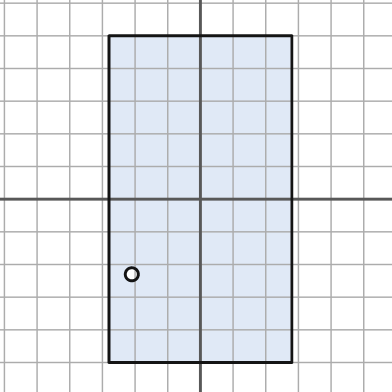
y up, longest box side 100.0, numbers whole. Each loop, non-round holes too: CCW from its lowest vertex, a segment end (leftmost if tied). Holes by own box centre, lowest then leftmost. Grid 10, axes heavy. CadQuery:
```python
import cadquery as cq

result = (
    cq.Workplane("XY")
    .moveTo(-28.0, -50.0)
    .lineTo(28.0, -50.0)
    .lineTo(28.0, 50.0)
    .lineTo(-28.0, 50.0)
    .close()
    .moveTo(-21.0, -23.0)
    .circle(2.0)
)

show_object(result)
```